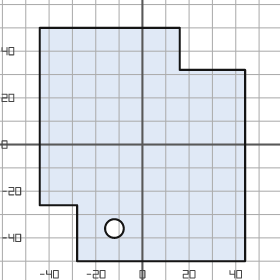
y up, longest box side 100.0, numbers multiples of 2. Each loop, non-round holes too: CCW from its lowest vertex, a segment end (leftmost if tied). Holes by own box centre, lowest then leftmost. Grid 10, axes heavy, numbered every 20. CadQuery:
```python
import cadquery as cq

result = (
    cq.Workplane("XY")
    .moveTo(-28.0, -50.0)
    .lineTo(44.0, -50.0)
    .lineTo(44.0, 32.0)
    .lineTo(16.0, 32.0)
    .lineTo(16.0, 50.0)
    .lineTo(-44.0, 50.0)
    .lineTo(-44.0, -26.0)
    .lineTo(-28.0, -26.0)
    .close()
    .moveTo(-12.0, -36.0)
    .circle(4.0)
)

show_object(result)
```